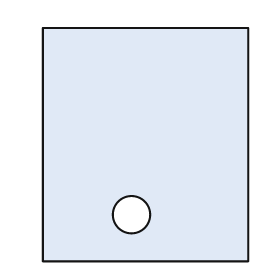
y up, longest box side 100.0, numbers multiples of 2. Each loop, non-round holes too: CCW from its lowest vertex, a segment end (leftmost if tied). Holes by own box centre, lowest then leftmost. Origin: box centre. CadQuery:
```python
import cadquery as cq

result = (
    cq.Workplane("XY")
    .moveTo(-44.0, -50.0)
    .lineTo(44.0, -50.0)
    .lineTo(44.0, 50.0)
    .lineTo(-44.0, 50.0)
    .close()
    .moveTo(-6.0, -30.0)
    .circle(8.0)
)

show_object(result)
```